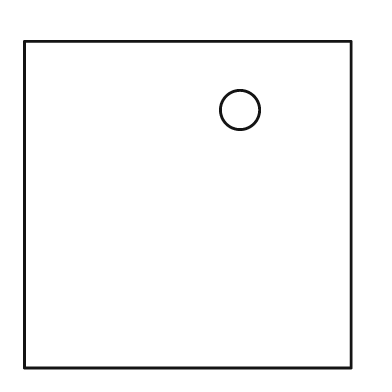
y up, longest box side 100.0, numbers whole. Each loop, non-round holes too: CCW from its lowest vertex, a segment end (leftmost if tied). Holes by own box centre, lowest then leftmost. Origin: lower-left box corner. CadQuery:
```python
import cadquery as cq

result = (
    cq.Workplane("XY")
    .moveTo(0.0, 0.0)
    .lineTo(100.0, 0.0)
    .lineTo(100.0, 100.0)
    .lineTo(0.0, 100.0)
    .close()
    .moveTo(66.0, 79.0)
    .circle(6.0)
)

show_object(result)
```